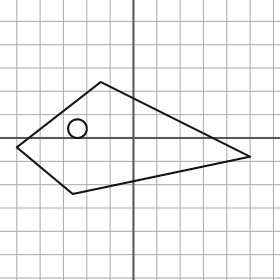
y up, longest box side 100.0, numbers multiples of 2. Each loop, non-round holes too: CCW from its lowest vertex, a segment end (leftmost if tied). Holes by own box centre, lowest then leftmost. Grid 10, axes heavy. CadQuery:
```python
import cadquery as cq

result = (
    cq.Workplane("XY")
    .moveTo(-26.0, -24.0)
    .lineTo(50.0, -8.0)
    .lineTo(-14.0, 24.0)
    .lineTo(-50.0, -4.0)
    .close()
    .moveTo(-24.0, 4.0)
    .circle(4.0)
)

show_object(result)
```